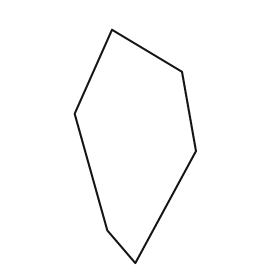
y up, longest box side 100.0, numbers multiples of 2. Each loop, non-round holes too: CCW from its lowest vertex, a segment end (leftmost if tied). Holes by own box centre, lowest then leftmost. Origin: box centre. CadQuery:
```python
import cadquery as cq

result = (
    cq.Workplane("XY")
    .moveTo(0.0, -50.0)
    .lineTo(26.0, -2.0)
    .lineTo(20.0, 32.0)
    .lineTo(-10.0, 50.0)
    .lineTo(-26.0, 14.0)
    .lineTo(-12.0, -36.0)
    .close()
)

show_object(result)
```